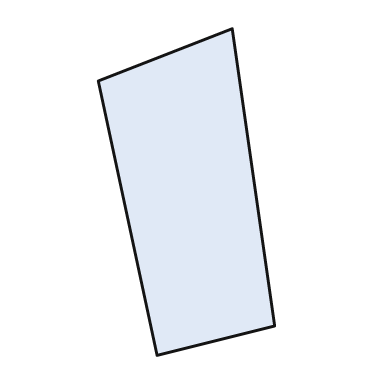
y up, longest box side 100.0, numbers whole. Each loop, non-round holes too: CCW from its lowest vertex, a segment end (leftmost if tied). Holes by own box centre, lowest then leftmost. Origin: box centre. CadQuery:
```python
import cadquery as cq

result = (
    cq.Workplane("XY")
    .moveTo(-9.0, -50.0)
    .lineTo(27.0, -41.0)
    .lineTo(14.0, 50.0)
    .lineTo(-27.0, 34.0)
    .close()
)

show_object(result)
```